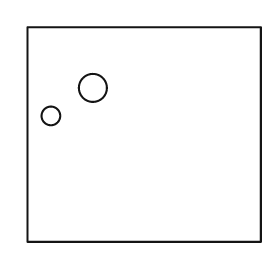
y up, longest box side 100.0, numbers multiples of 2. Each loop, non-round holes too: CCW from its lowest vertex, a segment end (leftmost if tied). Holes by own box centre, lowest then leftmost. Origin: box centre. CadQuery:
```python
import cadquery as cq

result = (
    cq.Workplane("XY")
    .moveTo(-50.0, -46.0)
    .lineTo(50.0, -46.0)
    .lineTo(50.0, 46.0)
    .lineTo(-50.0, 46.0)
    .close()
    .moveTo(-40.0, 8.0)
    .circle(4.0)
    .moveTo(-22.0, 20.0)
    .circle(6.0)
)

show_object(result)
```